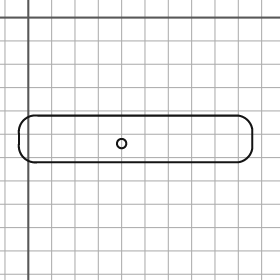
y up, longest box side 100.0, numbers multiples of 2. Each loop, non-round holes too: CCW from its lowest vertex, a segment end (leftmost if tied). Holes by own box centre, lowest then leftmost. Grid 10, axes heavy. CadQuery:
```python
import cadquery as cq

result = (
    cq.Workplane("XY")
    .moveTo(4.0, -62.0)
    .lineTo(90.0, -62.0)
    .threePointArc((94.0, -60.0), (96.0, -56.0))
    .lineTo(96.0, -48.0)
    .threePointArc((94.0, -44.0), (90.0, -42.0))
    .lineTo(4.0, -42.0)
    .threePointArc((-2.0, -44.0), (-4.0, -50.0))
    .lineTo(-4.0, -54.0)
    .threePointArc((-2.0, -60.0), (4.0, -62.0))
    .close()
    .moveTo(40.0, -54.0)
    .circle(2.0)
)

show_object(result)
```